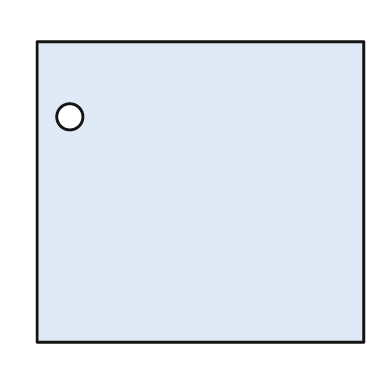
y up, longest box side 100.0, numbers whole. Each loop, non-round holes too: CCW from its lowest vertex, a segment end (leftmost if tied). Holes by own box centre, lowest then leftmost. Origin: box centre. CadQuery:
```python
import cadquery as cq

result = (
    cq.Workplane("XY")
    .moveTo(-50.0, -46.0)
    .lineTo(50.0, -46.0)
    .lineTo(50.0, 46.0)
    .lineTo(-50.0, 46.0)
    .close()
    .moveTo(-40.0, 23.0)
    .circle(4.0)
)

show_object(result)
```